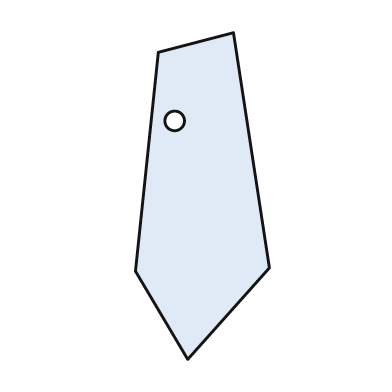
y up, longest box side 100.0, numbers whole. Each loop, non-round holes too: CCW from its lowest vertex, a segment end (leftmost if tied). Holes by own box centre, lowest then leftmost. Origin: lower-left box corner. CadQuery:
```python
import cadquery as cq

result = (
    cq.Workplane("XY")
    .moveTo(16.0, 0.0)
    .lineTo(41.0, 28.0)
    .lineTo(30.0, 100.0)
    .lineTo(7.0, 94.0)
    .lineTo(0.0, 27.0)
    .close()
    .moveTo(12.0, 73.0)
    .circle(3.0)
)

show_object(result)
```